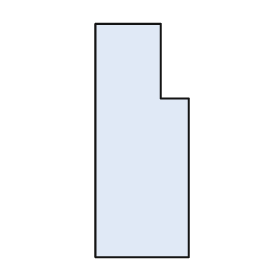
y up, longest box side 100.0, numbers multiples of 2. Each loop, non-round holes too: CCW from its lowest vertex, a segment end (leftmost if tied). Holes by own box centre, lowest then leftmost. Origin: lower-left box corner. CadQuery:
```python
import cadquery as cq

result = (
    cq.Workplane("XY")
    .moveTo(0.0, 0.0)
    .lineTo(40.0, 0.0)
    .lineTo(40.0, 68.0)
    .lineTo(28.0, 68.0)
    .lineTo(28.0, 100.0)
    .lineTo(0.0, 100.0)
    .close()
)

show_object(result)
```